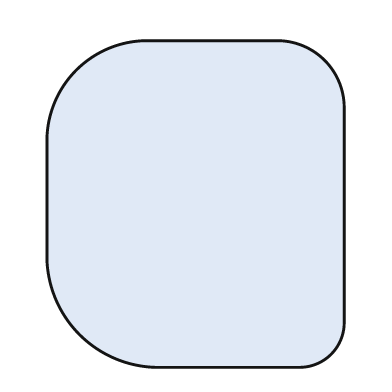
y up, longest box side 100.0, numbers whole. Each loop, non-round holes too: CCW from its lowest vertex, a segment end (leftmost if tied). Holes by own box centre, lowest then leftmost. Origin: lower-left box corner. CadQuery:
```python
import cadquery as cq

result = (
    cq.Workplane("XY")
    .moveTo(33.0, 0.0)
    .lineTo(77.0, 0.0)
    .threePointArc((87.0, 4.0), (91.0, 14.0))
    .lineTo(91.0, 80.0)
    .threePointArc((85.0, 94.0), (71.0, 100.0))
    .lineTo(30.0, 100.0)
    .threePointArc((9.0, 91.0), (0.0, 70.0))
    .lineTo(0.0, 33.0)
    .threePointArc((10.0, 10.0), (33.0, 0.0))
    .close()
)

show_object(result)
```